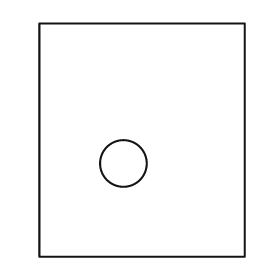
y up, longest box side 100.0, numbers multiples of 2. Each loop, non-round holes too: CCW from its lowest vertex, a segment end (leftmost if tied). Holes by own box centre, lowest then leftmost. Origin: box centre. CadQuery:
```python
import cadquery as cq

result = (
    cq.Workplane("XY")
    .moveTo(-44.0, -50.0)
    .lineTo(44.0, -50.0)
    .lineTo(44.0, 50.0)
    .lineTo(-44.0, 50.0)
    .close()
    .moveTo(-8.0, -10.0)
    .circle(10.0)
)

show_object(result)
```